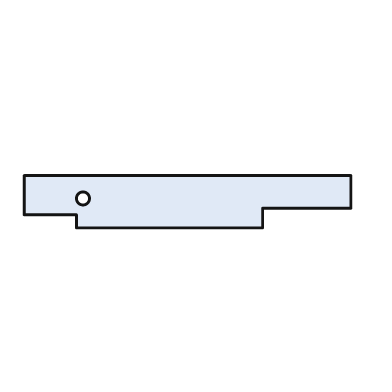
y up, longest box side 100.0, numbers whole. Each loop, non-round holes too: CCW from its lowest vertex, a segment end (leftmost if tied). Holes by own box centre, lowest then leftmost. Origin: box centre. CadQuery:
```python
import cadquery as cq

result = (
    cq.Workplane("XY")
    .moveTo(-34.0, -8.0)
    .lineTo(23.0, -8.0)
    .lineTo(23.0, -2.0)
    .lineTo(50.0, -2.0)
    .lineTo(50.0, 8.0)
    .lineTo(-50.0, 8.0)
    .lineTo(-50.0, -4.0)
    .lineTo(-34.0, -4.0)
    .close()
    .moveTo(-32.0, 1.0)
    .circle(2.0)
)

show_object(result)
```